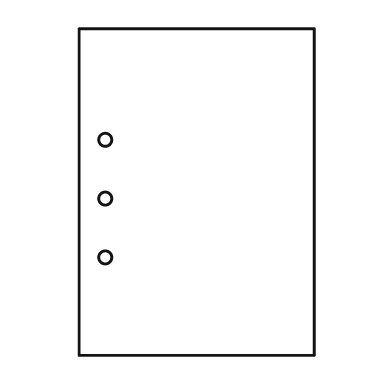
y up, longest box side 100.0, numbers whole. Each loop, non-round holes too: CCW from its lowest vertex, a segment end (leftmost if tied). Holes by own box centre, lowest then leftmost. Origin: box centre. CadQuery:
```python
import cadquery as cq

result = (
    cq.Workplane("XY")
    .moveTo(-36.0, -50.0)
    .lineTo(36.0, -50.0)
    .lineTo(36.0, 50.0)
    .lineTo(-36.0, 50.0)
    .close()
    .moveTo(-28.0, -20.0)
    .circle(2.0)
    .moveTo(-28.0, -2.0)
    .circle(2.0)
    .moveTo(-28.0, 16.0)
    .circle(2.0)
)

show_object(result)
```